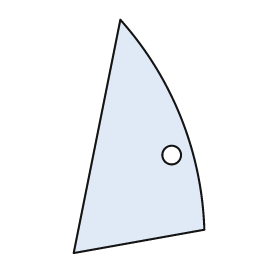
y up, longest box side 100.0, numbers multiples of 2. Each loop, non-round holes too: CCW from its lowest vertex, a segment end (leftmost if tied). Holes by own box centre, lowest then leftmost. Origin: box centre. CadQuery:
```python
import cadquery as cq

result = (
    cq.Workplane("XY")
    .moveTo(-28.0, -50.0)
    .lineTo(28.0, -40.0)
    .threePointArc((18.0, 8.0), (-8.0, 50.0))
    .close()
    .moveTo(14.0, -8.0)
    .circle(4.0)
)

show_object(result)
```